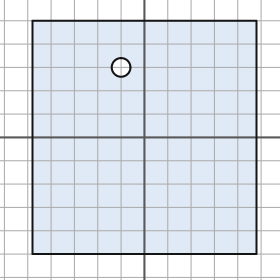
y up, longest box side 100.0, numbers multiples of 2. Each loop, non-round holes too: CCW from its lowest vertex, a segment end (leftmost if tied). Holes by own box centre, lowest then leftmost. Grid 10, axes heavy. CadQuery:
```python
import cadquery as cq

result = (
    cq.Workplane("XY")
    .moveTo(-48.0, -50.0)
    .lineTo(48.0, -50.0)
    .lineTo(48.0, 50.0)
    .lineTo(-48.0, 50.0)
    .close()
    .moveTo(-10.0, 30.0)
    .circle(4.0)
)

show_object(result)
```